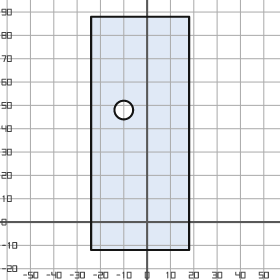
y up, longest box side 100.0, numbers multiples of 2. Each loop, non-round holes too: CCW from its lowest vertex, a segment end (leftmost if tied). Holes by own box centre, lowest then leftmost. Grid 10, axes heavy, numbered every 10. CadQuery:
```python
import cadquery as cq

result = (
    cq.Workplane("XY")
    .moveTo(-24.0, -12.0)
    .lineTo(18.0, -12.0)
    .lineTo(18.0, 88.0)
    .lineTo(-24.0, 88.0)
    .close()
    .moveTo(-10.0, 48.0)
    .circle(4.0)
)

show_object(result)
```